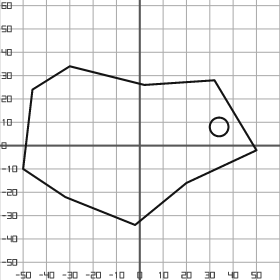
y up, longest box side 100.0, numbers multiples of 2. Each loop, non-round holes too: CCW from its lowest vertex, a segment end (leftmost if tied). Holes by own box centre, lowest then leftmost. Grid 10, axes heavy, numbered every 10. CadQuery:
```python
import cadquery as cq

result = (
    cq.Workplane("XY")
    .moveTo(-2.0, -34.0)
    .lineTo(20.0, -16.0)
    .lineTo(50.0, -2.0)
    .lineTo(32.0, 28.0)
    .lineTo(2.0, 26.0)
    .lineTo(-30.0, 34.0)
    .lineTo(-46.0, 24.0)
    .lineTo(-50.0, -10.0)
    .lineTo(-32.0, -22.0)
    .close()
    .moveTo(34.0, 8.0)
    .circle(4.0)
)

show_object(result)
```